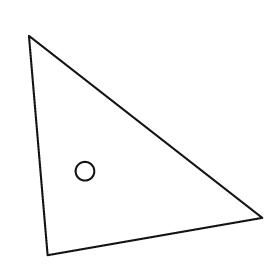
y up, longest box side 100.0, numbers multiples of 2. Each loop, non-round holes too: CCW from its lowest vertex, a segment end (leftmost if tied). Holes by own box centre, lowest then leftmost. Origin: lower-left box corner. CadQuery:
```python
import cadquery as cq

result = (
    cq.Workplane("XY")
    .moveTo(8.0, 0.0)
    .lineTo(100.0, 16.0)
    .lineTo(0.0, 94.0)
    .close()
    .moveTo(24.0, 36.0)
    .circle(4.0)
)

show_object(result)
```